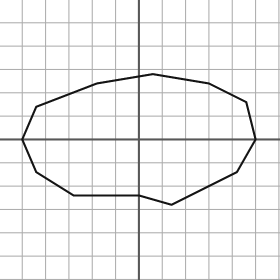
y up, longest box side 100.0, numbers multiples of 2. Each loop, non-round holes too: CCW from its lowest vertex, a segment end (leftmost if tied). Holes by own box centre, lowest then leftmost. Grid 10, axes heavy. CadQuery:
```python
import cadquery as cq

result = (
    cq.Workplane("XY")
    .moveTo(14.0, -28.0)
    .lineTo(42.0, -14.0)
    .lineTo(50.0, 0.0)
    .lineTo(46.0, 16.0)
    .lineTo(30.0, 24.0)
    .lineTo(6.0, 28.0)
    .lineTo(-18.0, 24.0)
    .lineTo(-44.0, 14.0)
    .lineTo(-50.0, 0.0)
    .lineTo(-44.0, -14.0)
    .lineTo(-28.0, -24.0)
    .lineTo(0.0, -24.0)
    .close()
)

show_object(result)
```